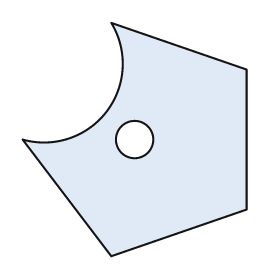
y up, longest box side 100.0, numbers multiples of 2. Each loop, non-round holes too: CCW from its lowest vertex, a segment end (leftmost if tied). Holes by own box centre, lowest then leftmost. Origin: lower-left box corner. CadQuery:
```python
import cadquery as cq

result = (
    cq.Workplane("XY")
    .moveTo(38.0, 0.0)
    .lineTo(96.0, 20.0)
    .lineTo(96.0, 80.0)
    .lineTo(38.0, 100.0)
    .threePointArc((36.0, 62.0), (0.0, 50.0))
    .close()
    .moveTo(48.0, 50.0)
    .circle(8.0)
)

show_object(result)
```